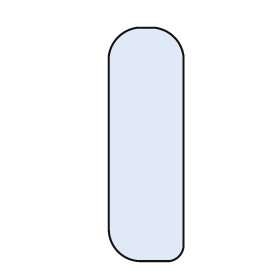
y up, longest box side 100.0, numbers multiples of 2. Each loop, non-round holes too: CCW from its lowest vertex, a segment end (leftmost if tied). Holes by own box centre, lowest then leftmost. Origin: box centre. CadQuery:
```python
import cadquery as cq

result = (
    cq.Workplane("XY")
    .moveTo(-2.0, -50.0)
    .lineTo(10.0, -50.0)
    .threePointArc((14.0, -48.0), (16.0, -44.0))
    .lineTo(16.0, 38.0)
    .threePointArc((12.0, 46.0), (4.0, 50.0))
    .lineTo(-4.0, 50.0)
    .threePointArc((-12.0, 46.0), (-16.0, 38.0))
    .lineTo(-16.0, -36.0)
    .threePointArc((-12.0, -46.0), (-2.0, -50.0))
    .close()
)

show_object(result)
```